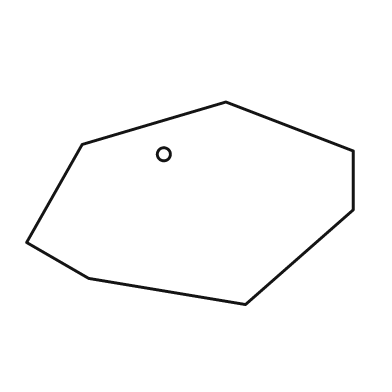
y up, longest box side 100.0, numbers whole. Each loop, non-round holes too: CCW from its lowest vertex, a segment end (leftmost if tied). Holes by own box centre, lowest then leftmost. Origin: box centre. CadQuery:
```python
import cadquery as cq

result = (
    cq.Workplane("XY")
    .moveTo(17.0, -31.0)
    .lineTo(50.0, -2.0)
    .lineTo(50.0, 16.0)
    .lineTo(11.0, 31.0)
    .lineTo(-33.0, 18.0)
    .lineTo(-50.0, -12.0)
    .lineTo(-31.0, -23.0)
    .close()
    .moveTo(-8.0, 15.0)
    .circle(2.0)
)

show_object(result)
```